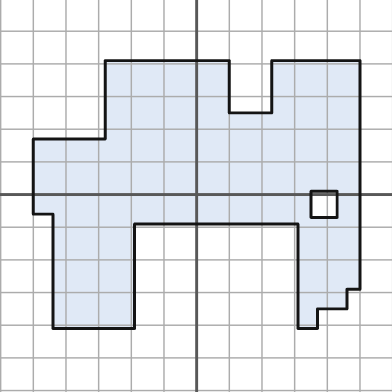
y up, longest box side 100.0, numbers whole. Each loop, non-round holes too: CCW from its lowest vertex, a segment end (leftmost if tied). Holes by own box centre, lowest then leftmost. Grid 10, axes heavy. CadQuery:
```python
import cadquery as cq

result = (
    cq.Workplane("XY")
    .moveTo(-44.0, -41.0)
    .lineTo(-19.0, -41.0)
    .lineTo(-19.0, -9.0)
    .lineTo(31.0, -9.0)
    .lineTo(31.0, -41.0)
    .lineTo(37.0, -41.0)
    .lineTo(37.0, -35.0)
    .lineTo(46.0, -35.0)
    .lineTo(46.0, -29.0)
    .lineTo(50.0, -29.0)
    .lineTo(50.0, 41.0)
    .lineTo(23.0, 41.0)
    .lineTo(23.0, 25.0)
    .lineTo(10.0, 25.0)
    .lineTo(10.0, 41.0)
    .lineTo(-28.0, 41.0)
    .lineTo(-28.0, 17.0)
    .lineTo(-50.0, 17.0)
    .lineTo(-50.0, -6.0)
    .lineTo(-44.0, -6.0)
    .close()
    .moveTo(35.0, -7.0)
    .lineTo(43.0, -7.0)
    .lineTo(43.0, 1.0)
    .lineTo(35.0, 1.0)
    .close()
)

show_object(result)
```